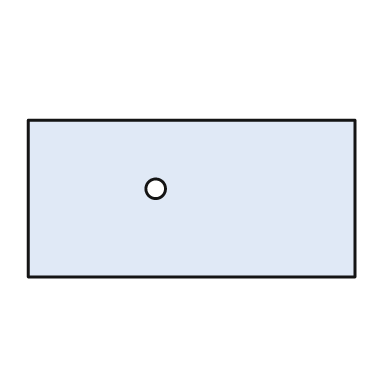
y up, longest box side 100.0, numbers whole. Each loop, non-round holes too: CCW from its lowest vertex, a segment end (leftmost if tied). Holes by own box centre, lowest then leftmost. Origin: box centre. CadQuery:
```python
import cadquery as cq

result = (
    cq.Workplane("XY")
    .moveTo(-50.0, -24.0)
    .lineTo(50.0, -24.0)
    .lineTo(50.0, 24.0)
    .lineTo(-50.0, 24.0)
    .close()
    .moveTo(-11.0, 3.0)
    .circle(3.0)
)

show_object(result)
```